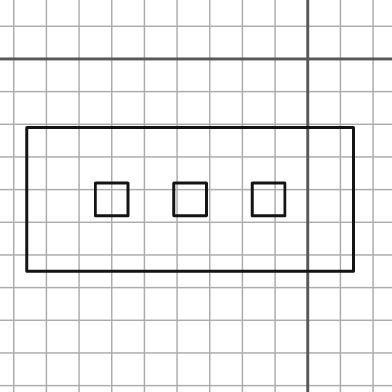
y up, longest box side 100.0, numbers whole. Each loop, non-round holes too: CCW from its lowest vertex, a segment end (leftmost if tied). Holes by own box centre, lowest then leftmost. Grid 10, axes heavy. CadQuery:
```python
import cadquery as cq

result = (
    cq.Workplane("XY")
    .moveTo(-86.0, -65.0)
    .lineTo(14.0, -65.0)
    .lineTo(14.0, -21.0)
    .lineTo(-86.0, -21.0)
    .close()
    .moveTo(-65.0, -48.0)
    .lineTo(-55.0, -48.0)
    .lineTo(-55.0, -38.0)
    .lineTo(-65.0, -38.0)
    .close()
    .moveTo(-41.0, -48.0)
    .lineTo(-31.0, -48.0)
    .lineTo(-31.0, -38.0)
    .lineTo(-41.0, -38.0)
    .close()
    .moveTo(-17.0, -48.0)
    .lineTo(-7.0, -48.0)
    .lineTo(-7.0, -38.0)
    .lineTo(-17.0, -38.0)
    .close()
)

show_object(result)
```